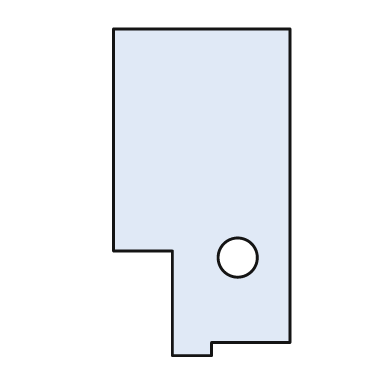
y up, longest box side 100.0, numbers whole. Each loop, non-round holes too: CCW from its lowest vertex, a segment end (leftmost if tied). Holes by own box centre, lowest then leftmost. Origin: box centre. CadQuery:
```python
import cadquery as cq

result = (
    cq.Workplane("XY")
    .moveTo(-9.0, -50.0)
    .lineTo(3.0, -50.0)
    .lineTo(3.0, -46.0)
    .lineTo(27.0, -46.0)
    .lineTo(27.0, 50.0)
    .lineTo(-27.0, 50.0)
    .lineTo(-27.0, -18.0)
    .lineTo(-9.0, -18.0)
    .close()
    .moveTo(11.0, -20.0)
    .circle(6.0)
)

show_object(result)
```